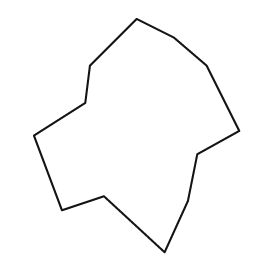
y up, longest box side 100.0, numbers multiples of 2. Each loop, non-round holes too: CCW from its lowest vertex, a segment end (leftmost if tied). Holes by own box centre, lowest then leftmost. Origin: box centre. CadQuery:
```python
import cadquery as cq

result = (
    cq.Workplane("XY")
    .moveTo(12.0, -50.0)
    .lineTo(22.0, -28.0)
    .lineTo(26.0, -8.0)
    .lineTo(44.0, 2.0)
    .lineTo(30.0, 30.0)
    .lineTo(16.0, 42.0)
    .lineTo(0.0, 50.0)
    .lineTo(-20.0, 30.0)
    .lineTo(-22.0, 14.0)
    .lineTo(-44.0, 0.0)
    .lineTo(-32.0, -32.0)
    .lineTo(-14.0, -26.0)
    .close()
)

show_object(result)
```